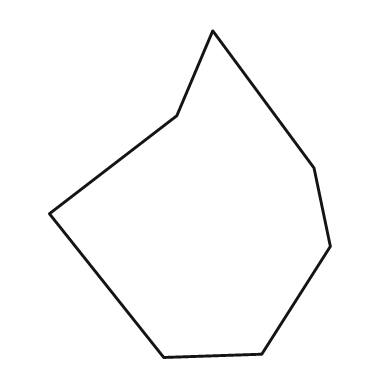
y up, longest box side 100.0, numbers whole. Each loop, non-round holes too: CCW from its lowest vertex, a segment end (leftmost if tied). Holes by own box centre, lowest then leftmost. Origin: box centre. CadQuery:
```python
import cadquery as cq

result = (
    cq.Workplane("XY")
    .moveTo(-8.0, -50.0)
    .lineTo(22.0, -49.0)
    .lineTo(43.0, -16.0)
    .lineTo(38.0, 8.0)
    .lineTo(7.0, 50.0)
    .lineTo(-4.0, 24.0)
    .lineTo(-43.0, -6.0)
    .close()
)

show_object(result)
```